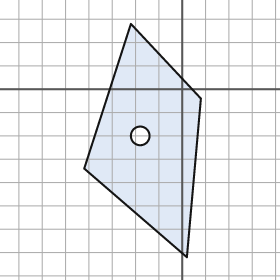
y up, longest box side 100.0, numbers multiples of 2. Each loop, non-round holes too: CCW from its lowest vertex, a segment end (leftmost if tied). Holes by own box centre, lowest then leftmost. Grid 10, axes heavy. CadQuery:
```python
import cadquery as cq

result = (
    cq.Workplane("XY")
    .moveTo(2.0, -72.0)
    .lineTo(8.0, -4.0)
    .lineTo(-22.0, 28.0)
    .lineTo(-42.0, -34.0)
    .close()
    .moveTo(-18.0, -20.0)
    .circle(4.0)
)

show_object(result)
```